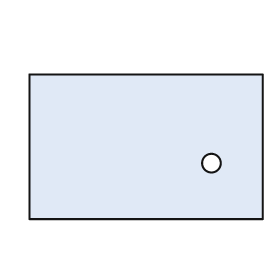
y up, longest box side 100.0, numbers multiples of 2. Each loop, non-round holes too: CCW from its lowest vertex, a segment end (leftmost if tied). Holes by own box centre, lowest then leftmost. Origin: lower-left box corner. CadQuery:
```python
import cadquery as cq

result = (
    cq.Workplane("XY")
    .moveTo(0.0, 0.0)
    .lineTo(100.0, 0.0)
    .lineTo(100.0, 62.0)
    .lineTo(0.0, 62.0)
    .close()
    .moveTo(78.0, 24.0)
    .circle(4.0)
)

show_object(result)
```